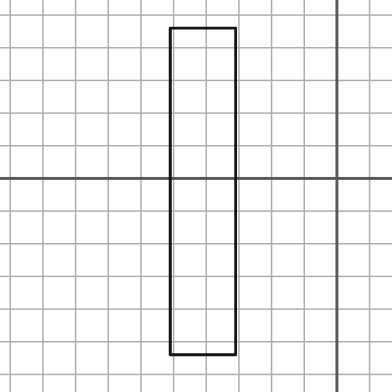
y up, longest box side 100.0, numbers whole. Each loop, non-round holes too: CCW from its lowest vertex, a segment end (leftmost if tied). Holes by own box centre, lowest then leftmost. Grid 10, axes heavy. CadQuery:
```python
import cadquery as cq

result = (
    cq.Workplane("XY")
    .moveTo(-51.0, -54.0)
    .lineTo(-31.0, -54.0)
    .lineTo(-31.0, 46.0)
    .lineTo(-51.0, 46.0)
    .close()
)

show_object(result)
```